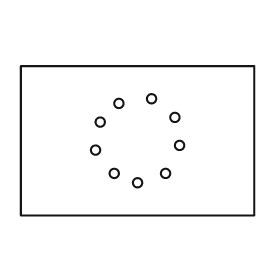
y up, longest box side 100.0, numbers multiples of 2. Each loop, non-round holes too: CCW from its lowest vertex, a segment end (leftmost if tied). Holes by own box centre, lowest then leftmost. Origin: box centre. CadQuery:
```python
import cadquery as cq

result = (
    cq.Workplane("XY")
    .moveTo(-50.0, -32.0)
    .lineTo(50.0, -32.0)
    .lineTo(50.0, 32.0)
    .lineTo(-50.0, 32.0)
    .close()
    .moveTo(0.0, -18.0)
    .circle(2.0)
    .moveTo(-10.0, -14.0)
    .circle(2.0)
    .moveTo(12.0, -14.0)
    .circle(2.0)
    .moveTo(-18.0, -4.0)
    .circle(2.0)
    .moveTo(18.0, -2.0)
    .circle(2.0)
    .moveTo(-16.0, 8.0)
    .circle(2.0)
    .moveTo(16.0, 10.0)
    .circle(2.0)
    .moveTo(-8.0, 16.0)
    .circle(2.0)
    .moveTo(6.0, 18.0)
    .circle(2.0)
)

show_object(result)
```